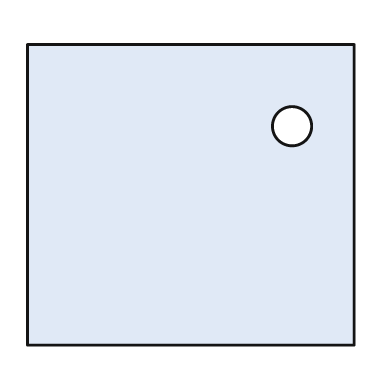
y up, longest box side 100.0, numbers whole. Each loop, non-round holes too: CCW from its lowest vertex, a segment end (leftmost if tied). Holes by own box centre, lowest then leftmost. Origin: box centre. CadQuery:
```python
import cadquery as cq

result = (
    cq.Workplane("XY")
    .moveTo(-50.0, -46.0)
    .lineTo(50.0, -46.0)
    .lineTo(50.0, 46.0)
    .lineTo(-50.0, 46.0)
    .close()
    .moveTo(31.0, 21.0)
    .circle(6.0)
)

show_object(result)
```